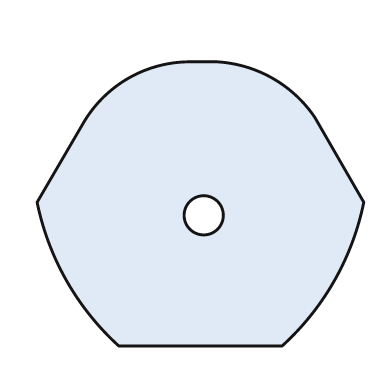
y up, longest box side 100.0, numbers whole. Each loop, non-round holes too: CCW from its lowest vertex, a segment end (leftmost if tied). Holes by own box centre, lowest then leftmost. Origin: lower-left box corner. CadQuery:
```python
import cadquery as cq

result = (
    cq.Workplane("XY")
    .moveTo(25.0, 0.0)
    .lineTo(75.0, 0.0)
    .threePointArc((91.0, 20.0), (100.0, 44.0))
    .lineTo(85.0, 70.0)
    .threePointArc((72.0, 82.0), (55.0, 87.0))
    .lineTo(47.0, 87.0)
    .threePointArc((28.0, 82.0), (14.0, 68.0))
    .lineTo(0.0, 44.0)
    .threePointArc((9.0, 20.0), (25.0, 0.0))
    .close()
    .moveTo(51.0, 40.0)
    .circle(6.0)
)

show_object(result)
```